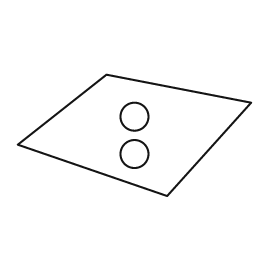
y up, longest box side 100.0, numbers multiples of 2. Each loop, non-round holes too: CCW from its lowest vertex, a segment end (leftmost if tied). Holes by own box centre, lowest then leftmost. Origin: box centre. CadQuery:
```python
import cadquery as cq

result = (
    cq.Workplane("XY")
    .moveTo(14.0, -26.0)
    .lineTo(50.0, 14.0)
    .lineTo(-12.0, 26.0)
    .lineTo(-50.0, -4.0)
    .close()
    .moveTo(0.0, -8.0)
    .circle(6.0)
    .moveTo(0.0, 8.0)
    .circle(6.0)
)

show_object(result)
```